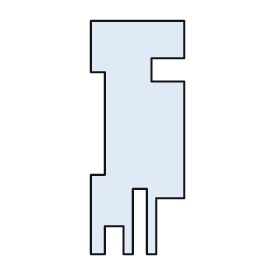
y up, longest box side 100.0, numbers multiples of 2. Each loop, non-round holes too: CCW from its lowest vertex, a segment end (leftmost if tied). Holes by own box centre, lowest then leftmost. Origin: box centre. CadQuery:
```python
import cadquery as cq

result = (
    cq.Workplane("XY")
    .moveTo(-20.0, -50.0)
    .lineTo(-14.0, -50.0)
    .lineTo(-14.0, -38.0)
    .lineTo(-6.0, -38.0)
    .lineTo(-6.0, -50.0)
    .lineTo(-2.0, -50.0)
    .lineTo(-2.0, -22.0)
    .lineTo(4.0, -22.0)
    .lineTo(4.0, -50.0)
    .lineTo(8.0, -50.0)
    .lineTo(8.0, -26.0)
    .lineTo(20.0, -26.0)
    .lineTo(20.0, 24.0)
    .lineTo(6.0, 24.0)
    .lineTo(6.0, 34.0)
    .lineTo(20.0, 34.0)
    .lineTo(20.0, 50.0)
    .lineTo(-20.0, 50.0)
    .lineTo(-20.0, 28.0)
    .lineTo(-14.0, 28.0)
    .lineTo(-14.0, -16.0)
    .lineTo(-20.0, -16.0)
    .close()
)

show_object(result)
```